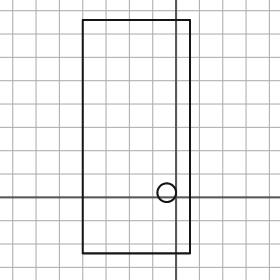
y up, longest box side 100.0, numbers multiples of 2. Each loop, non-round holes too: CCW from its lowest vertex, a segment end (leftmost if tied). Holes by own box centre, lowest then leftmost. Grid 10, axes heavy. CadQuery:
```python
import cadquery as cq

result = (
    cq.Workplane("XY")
    .moveTo(-40.0, -24.0)
    .lineTo(6.0, -24.0)
    .lineTo(6.0, 76.0)
    .lineTo(-40.0, 76.0)
    .close()
    .moveTo(-4.0, 2.0)
    .circle(4.0)
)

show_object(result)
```